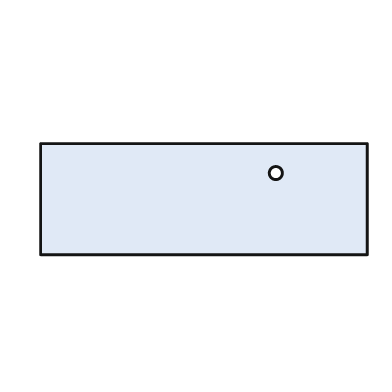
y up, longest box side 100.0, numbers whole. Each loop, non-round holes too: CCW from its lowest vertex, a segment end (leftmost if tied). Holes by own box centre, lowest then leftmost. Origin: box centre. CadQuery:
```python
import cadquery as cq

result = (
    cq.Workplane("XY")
    .moveTo(-50.0, -17.0)
    .lineTo(50.0, -17.0)
    .lineTo(50.0, 17.0)
    .lineTo(-50.0, 17.0)
    .close()
    .moveTo(22.0, 8.0)
    .circle(2.0)
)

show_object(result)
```